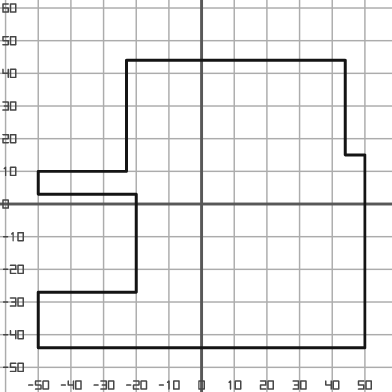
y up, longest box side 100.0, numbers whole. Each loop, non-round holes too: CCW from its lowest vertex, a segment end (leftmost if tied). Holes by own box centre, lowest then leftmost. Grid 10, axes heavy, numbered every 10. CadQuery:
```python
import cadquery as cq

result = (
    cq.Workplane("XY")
    .moveTo(-50.0, -44.0)
    .lineTo(50.0, -44.0)
    .lineTo(50.0, 15.0)
    .lineTo(44.0, 15.0)
    .lineTo(44.0, 44.0)
    .lineTo(-23.0, 44.0)
    .lineTo(-23.0, 10.0)
    .lineTo(-50.0, 10.0)
    .lineTo(-50.0, 3.0)
    .lineTo(-20.0, 3.0)
    .lineTo(-20.0, -27.0)
    .lineTo(-50.0, -27.0)
    .close()
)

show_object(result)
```